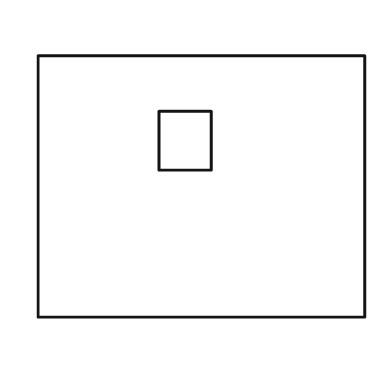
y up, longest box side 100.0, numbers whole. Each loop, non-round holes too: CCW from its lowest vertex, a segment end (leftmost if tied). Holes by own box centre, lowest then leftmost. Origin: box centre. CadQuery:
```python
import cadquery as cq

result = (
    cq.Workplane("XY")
    .moveTo(-50.0, -40.0)
    .lineTo(50.0, -40.0)
    .lineTo(50.0, 40.0)
    .lineTo(-50.0, 40.0)
    .close()
    .moveTo(-13.0, 5.0)
    .lineTo(3.0, 5.0)
    .lineTo(3.0, 23.0)
    .lineTo(-13.0, 23.0)
    .close()
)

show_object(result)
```